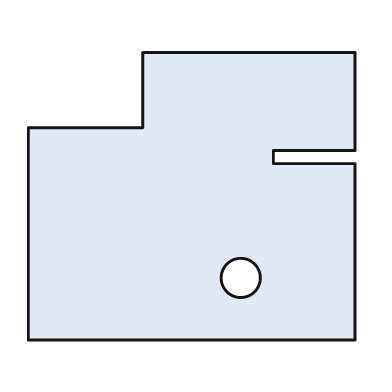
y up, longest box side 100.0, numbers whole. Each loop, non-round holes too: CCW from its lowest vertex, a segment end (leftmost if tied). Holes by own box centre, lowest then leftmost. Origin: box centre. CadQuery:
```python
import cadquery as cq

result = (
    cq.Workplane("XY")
    .moveTo(-50.0, -44.0)
    .lineTo(50.0, -44.0)
    .lineTo(50.0, 10.0)
    .lineTo(25.0, 10.0)
    .lineTo(25.0, 14.0)
    .lineTo(50.0, 14.0)
    .lineTo(50.0, 44.0)
    .lineTo(-15.0, 44.0)
    .lineTo(-15.0, 21.0)
    .lineTo(-50.0, 21.0)
    .close()
    .moveTo(15.0, -25.0)
    .circle(6.0)
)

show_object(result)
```